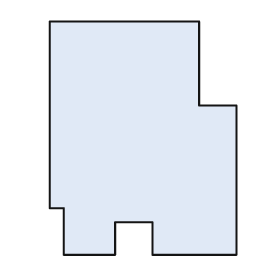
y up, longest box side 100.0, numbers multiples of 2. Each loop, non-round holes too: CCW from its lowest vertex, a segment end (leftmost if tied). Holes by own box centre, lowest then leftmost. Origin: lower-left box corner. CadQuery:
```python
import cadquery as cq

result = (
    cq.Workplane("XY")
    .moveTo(6.0, 0.0)
    .lineTo(28.0, 0.0)
    .lineTo(28.0, 14.0)
    .lineTo(44.0, 14.0)
    .lineTo(44.0, 0.0)
    .lineTo(80.0, 0.0)
    .lineTo(80.0, 64.0)
    .lineTo(64.0, 64.0)
    .lineTo(64.0, 100.0)
    .lineTo(0.0, 100.0)
    .lineTo(0.0, 20.0)
    .lineTo(6.0, 20.0)
    .close()
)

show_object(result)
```